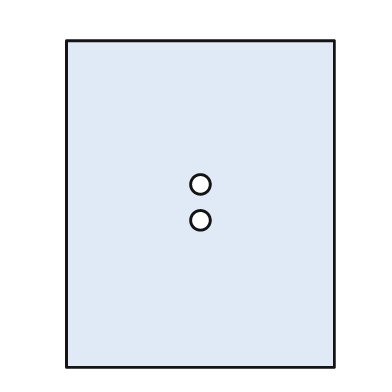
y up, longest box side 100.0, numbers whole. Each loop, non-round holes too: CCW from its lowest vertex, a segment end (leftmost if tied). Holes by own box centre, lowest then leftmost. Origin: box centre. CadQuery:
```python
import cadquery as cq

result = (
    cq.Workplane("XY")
    .moveTo(-41.0, -50.0)
    .lineTo(41.0, -50.0)
    .lineTo(41.0, 50.0)
    .lineTo(-41.0, 50.0)
    .close()
    .moveTo(0.0, -5.0)
    .circle(3.0)
    .moveTo(0.0, 6.0)
    .circle(3.0)
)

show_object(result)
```